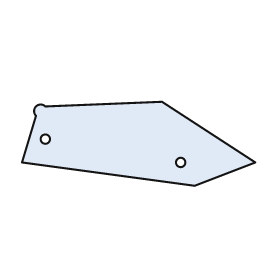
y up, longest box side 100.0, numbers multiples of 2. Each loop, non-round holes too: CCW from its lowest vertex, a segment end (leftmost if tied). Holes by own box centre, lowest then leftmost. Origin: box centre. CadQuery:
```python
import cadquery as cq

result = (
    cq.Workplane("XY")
    .moveTo(24.0, -18.0)
    .lineTo(50.0, -8.0)
    .lineTo(10.0, 18.0)
    .lineTo(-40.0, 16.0)
    .threePointArc((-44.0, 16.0), (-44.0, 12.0))
    .lineTo(-50.0, -8.0)
    .close()
    .moveTo(18.0, -8.0)
    .circle(2.0)
    .moveTo(-40.0, 2.0)
    .circle(2.0)
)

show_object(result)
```